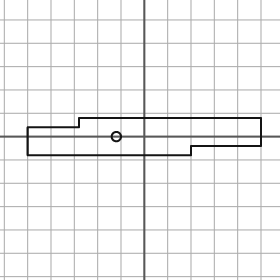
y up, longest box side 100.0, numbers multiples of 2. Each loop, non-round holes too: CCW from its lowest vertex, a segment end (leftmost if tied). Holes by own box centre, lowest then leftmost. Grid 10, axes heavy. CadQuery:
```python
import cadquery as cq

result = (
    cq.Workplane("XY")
    .moveTo(-50.0, -8.0)
    .lineTo(20.0, -8.0)
    .lineTo(20.0, -4.0)
    .lineTo(50.0, -4.0)
    .lineTo(50.0, 8.0)
    .lineTo(-28.0, 8.0)
    .lineTo(-28.0, 4.0)
    .lineTo(-50.0, 4.0)
    .close()
    .moveTo(-12.0, 0.0)
    .circle(2.0)
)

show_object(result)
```